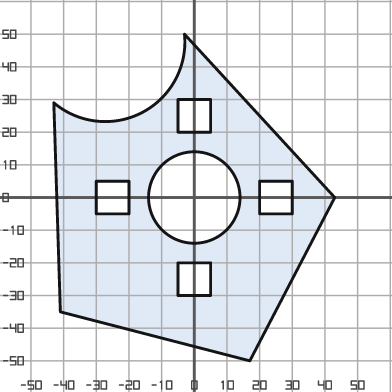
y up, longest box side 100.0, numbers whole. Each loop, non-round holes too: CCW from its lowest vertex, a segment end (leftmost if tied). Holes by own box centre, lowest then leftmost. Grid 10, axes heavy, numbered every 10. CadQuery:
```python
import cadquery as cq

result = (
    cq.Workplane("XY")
    .moveTo(17.0, -50.0)
    .lineTo(43.0, 0.0)
    .lineTo(-3.0, 50.0)
    .threePointArc((-16.0, 26.0), (-43.0, 29.0))
    .lineTo(-41.0, -35.0)
    .close()
    .moveTo(-5.0, -30.0)
    .lineTo(5.0, -30.0)
    .lineTo(5.0, -20.0)
    .lineTo(-5.0, -20.0)
    .close()
    .moveTo(-30.0, -5.0)
    .lineTo(-20.0, -5.0)
    .lineTo(-20.0, 5.0)
    .lineTo(-30.0, 5.0)
    .close()
    .moveTo(0.0, 0.0)
    .circle(14.0)
    .moveTo(20.0, -5.0)
    .lineTo(30.0, -5.0)
    .lineTo(30.0, 5.0)
    .lineTo(20.0, 5.0)
    .close()
    .moveTo(-5.0, 20.0)
    .lineTo(5.0, 20.0)
    .lineTo(5.0, 30.0)
    .lineTo(-5.0, 30.0)
    .close()
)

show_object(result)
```